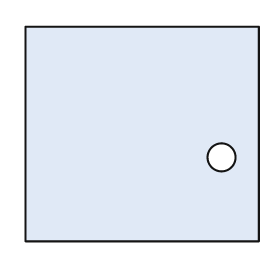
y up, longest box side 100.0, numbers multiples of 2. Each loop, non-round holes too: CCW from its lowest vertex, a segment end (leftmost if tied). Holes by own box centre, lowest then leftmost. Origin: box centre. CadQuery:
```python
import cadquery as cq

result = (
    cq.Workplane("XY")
    .moveTo(-50.0, -46.0)
    .lineTo(50.0, -46.0)
    .lineTo(50.0, 46.0)
    .lineTo(-50.0, 46.0)
    .close()
    .moveTo(34.0, -10.0)
    .circle(6.0)
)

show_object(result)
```